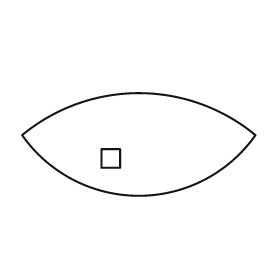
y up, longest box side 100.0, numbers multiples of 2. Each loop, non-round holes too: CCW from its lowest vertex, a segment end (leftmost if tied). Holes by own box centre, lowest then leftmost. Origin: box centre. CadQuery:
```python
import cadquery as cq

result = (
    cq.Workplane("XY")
    .moveTo(-50.0, 4.0)
    .threePointArc((0.0, -22.0), (50.0, 4.0))
    .threePointArc((0.0, 22.0), (-50.0, 4.0))
    .close()
    .moveTo(-16.0, -10.0)
    .lineTo(-8.0, -10.0)
    .lineTo(-8.0, -2.0)
    .lineTo(-16.0, -2.0)
    .close()
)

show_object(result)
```